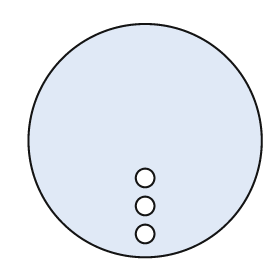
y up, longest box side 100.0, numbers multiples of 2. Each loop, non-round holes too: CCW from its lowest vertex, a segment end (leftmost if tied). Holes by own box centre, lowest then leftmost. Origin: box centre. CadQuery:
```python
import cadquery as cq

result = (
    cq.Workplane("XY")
    .moveTo(0.0, 0.0)
    .circle(50.0)
    .moveTo(0.0, -40.0)
    .circle(4.0)
    .moveTo(0.0, -28.0)
    .circle(4.0)
    .moveTo(0.0, -16.0)
    .circle(4.0)
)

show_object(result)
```